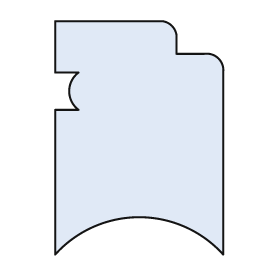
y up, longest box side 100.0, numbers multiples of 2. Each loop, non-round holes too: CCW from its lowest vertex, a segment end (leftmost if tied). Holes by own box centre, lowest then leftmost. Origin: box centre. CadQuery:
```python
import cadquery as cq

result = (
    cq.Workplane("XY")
    .moveTo(-36.0, -50.0)
    .threePointArc((0.0, -34.0), (36.0, -50.0))
    .lineTo(36.0, 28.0)
    .threePointArc((34.0, 34.0), (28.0, 36.0))
    .lineTo(16.0, 36.0)
    .lineTo(16.0, 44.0)
    .threePointArc((14.0, 48.0), (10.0, 50.0))
    .lineTo(-36.0, 50.0)
    .lineTo(-36.0, 28.0)
    .lineTo(-26.0, 28.0)
    .threePointArc((-30.0, 20.0), (-26.0, 12.0))
    .lineTo(-36.0, 12.0)
    .close()
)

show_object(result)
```